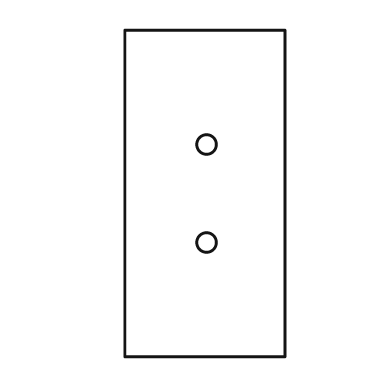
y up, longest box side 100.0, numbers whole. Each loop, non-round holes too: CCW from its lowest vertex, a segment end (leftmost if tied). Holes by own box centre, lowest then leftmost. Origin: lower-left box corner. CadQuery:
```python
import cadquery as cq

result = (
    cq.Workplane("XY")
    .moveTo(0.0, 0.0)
    .lineTo(49.0, 0.0)
    .lineTo(49.0, 100.0)
    .lineTo(0.0, 100.0)
    .close()
    .moveTo(25.0, 35.0)
    .circle(3.0)
    .moveTo(25.0, 65.0)
    .circle(3.0)
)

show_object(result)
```